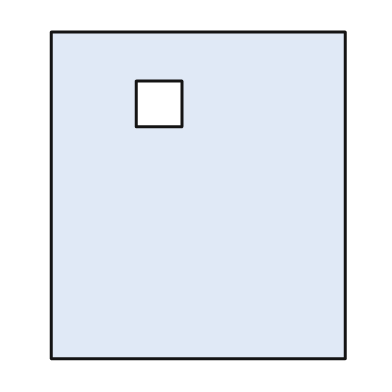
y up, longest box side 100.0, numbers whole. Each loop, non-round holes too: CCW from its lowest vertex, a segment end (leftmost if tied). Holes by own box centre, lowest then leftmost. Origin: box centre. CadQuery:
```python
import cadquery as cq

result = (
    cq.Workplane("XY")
    .moveTo(-45.0, -50.0)
    .lineTo(45.0, -50.0)
    .lineTo(45.0, 50.0)
    .lineTo(-45.0, 50.0)
    .close()
    .moveTo(-19.0, 21.0)
    .lineTo(-5.0, 21.0)
    .lineTo(-5.0, 35.0)
    .lineTo(-19.0, 35.0)
    .close()
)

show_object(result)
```